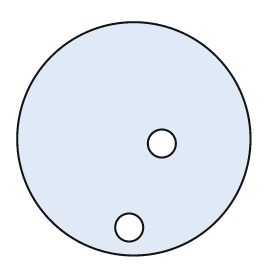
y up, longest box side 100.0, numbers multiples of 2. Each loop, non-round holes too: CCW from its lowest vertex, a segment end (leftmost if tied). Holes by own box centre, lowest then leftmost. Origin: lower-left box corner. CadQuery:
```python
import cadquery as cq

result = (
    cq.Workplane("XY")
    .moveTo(50.0, 50.0)
    .circle(50.0)
    .moveTo(48.0, 12.0)
    .circle(6.0)
    .moveTo(62.0, 48.0)
    .circle(6.0)
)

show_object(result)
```